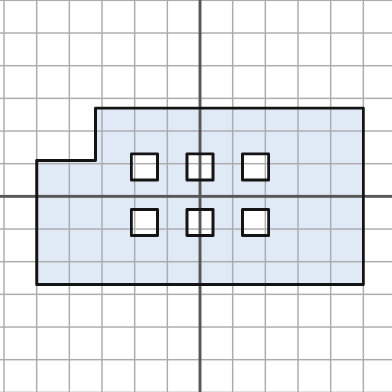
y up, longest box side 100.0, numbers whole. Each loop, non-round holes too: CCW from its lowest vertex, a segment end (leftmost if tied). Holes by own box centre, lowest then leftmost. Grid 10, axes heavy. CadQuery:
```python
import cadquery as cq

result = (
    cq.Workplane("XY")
    .moveTo(-50.0, -27.0)
    .lineTo(50.0, -27.0)
    .lineTo(50.0, 27.0)
    .lineTo(-32.0, 27.0)
    .lineTo(-32.0, 11.0)
    .lineTo(-50.0, 11.0)
    .close()
    .moveTo(-21.0, -12.0)
    .lineTo(-13.0, -12.0)
    .lineTo(-13.0, -4.0)
    .lineTo(-21.0, -4.0)
    .close()
    .moveTo(-4.0, -12.0)
    .lineTo(4.0, -12.0)
    .lineTo(4.0, -4.0)
    .lineTo(-4.0, -4.0)
    .close()
    .moveTo(13.0, -12.0)
    .lineTo(21.0, -12.0)
    .lineTo(21.0, -4.0)
    .lineTo(13.0, -4.0)
    .close()
    .moveTo(-21.0, 5.0)
    .lineTo(-13.0, 5.0)
    .lineTo(-13.0, 13.0)
    .lineTo(-21.0, 13.0)
    .close()
    .moveTo(-4.0, 5.0)
    .lineTo(4.0, 5.0)
    .lineTo(4.0, 13.0)
    .lineTo(-4.0, 13.0)
    .close()
    .moveTo(13.0, 5.0)
    .lineTo(21.0, 5.0)
    .lineTo(21.0, 13.0)
    .lineTo(13.0, 13.0)
    .close()
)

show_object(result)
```